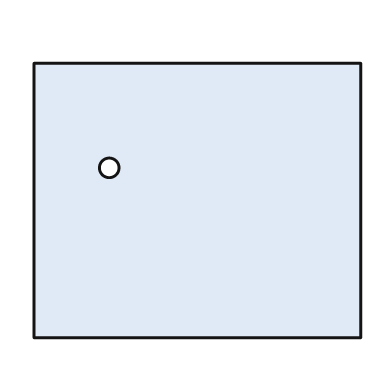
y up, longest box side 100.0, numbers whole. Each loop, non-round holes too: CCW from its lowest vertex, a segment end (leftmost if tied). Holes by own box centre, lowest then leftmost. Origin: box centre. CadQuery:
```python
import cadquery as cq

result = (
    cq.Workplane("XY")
    .moveTo(-50.0, -42.0)
    .lineTo(50.0, -42.0)
    .lineTo(50.0, 42.0)
    .lineTo(-50.0, 42.0)
    .close()
    .moveTo(-27.0, 10.0)
    .circle(3.0)
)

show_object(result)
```